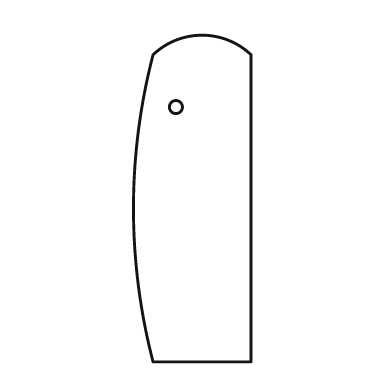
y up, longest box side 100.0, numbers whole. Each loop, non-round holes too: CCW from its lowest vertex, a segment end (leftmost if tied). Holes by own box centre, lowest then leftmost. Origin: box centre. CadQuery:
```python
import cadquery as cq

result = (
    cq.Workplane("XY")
    .moveTo(-12.0, -50.0)
    .lineTo(18.0, -50.0)
    .lineTo(18.0, 44.0)
    .threePointArc((3.0, 50.0), (-12.0, 44.0))
    .threePointArc((-18.0, -3.0), (-12.0, -50.0))
    .close()
    .moveTo(-5.0, 28.0)
    .circle(2.0)
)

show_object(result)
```